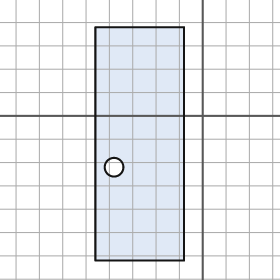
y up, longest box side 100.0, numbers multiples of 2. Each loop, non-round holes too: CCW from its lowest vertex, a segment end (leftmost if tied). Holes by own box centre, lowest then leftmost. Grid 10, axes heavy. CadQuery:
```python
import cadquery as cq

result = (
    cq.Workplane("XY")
    .moveTo(-46.0, -62.0)
    .lineTo(-8.0, -62.0)
    .lineTo(-8.0, 38.0)
    .lineTo(-46.0, 38.0)
    .close()
    .moveTo(-38.0, -22.0)
    .circle(4.0)
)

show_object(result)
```